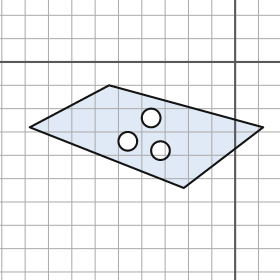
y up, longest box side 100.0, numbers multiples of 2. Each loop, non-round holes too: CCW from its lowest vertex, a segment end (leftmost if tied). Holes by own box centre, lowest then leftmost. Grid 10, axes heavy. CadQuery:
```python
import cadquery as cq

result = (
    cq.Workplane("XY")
    .moveTo(-22.0, -54.0)
    .lineTo(12.0, -28.0)
    .lineTo(-54.0, -10.0)
    .lineTo(-88.0, -28.0)
    .close()
    .moveTo(-32.0, -38.0)
    .circle(4.0)
    .moveTo(-46.0, -34.0)
    .circle(4.0)
    .moveTo(-36.0, -24.0)
    .circle(4.0)
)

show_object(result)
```